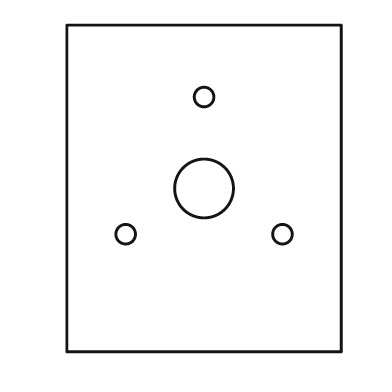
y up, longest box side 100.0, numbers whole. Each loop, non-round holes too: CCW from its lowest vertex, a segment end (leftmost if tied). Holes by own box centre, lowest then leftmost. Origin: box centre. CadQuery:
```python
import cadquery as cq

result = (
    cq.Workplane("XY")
    .moveTo(-42.0, -50.0)
    .lineTo(42.0, -50.0)
    .lineTo(42.0, 50.0)
    .lineTo(-42.0, 50.0)
    .close()
    .moveTo(-24.0, -14.0)
    .circle(3.0)
    .moveTo(24.0, -14.0)
    .circle(3.0)
    .moveTo(0.0, 0.0)
    .circle(9.0)
    .moveTo(0.0, 28.0)
    .circle(3.0)
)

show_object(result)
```